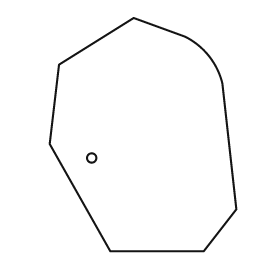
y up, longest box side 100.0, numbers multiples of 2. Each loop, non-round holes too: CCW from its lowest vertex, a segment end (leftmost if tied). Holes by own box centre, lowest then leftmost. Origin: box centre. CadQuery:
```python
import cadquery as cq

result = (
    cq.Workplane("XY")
    .moveTo(-14.0, -50.0)
    .lineTo(26.0, -50.0)
    .lineTo(40.0, -32.0)
    .lineTo(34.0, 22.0)
    .threePointArc((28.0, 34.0), (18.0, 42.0))
    .lineTo(-4.0, 50.0)
    .lineTo(-36.0, 30.0)
    .lineTo(-40.0, -4.0)
    .close()
    .moveTo(-22.0, -10.0)
    .circle(2.0)
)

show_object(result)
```